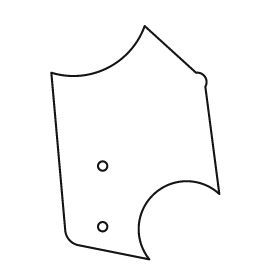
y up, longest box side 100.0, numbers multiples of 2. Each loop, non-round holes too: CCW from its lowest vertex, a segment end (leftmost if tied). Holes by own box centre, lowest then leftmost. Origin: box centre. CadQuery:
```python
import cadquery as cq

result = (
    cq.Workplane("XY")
    .moveTo(6.0, -50.0)
    .threePointArc((8.0, -22.0), (36.0, -22.0))
    .lineTo(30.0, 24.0)
    .threePointArc((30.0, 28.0), (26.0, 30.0))
    .lineTo(4.0, 50.0)
    .threePointArc((-12.0, 32.0), (-36.0, 30.0))
    .lineTo(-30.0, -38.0)
    .threePointArc((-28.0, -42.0), (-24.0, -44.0))
    .close()
    .moveTo(-14.0, -36.0)
    .circle(2.0)
    .moveTo(-14.0, -10.0)
    .circle(2.0)
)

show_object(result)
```